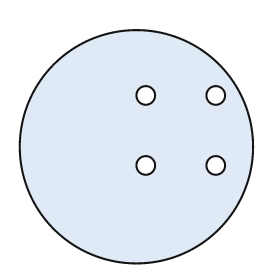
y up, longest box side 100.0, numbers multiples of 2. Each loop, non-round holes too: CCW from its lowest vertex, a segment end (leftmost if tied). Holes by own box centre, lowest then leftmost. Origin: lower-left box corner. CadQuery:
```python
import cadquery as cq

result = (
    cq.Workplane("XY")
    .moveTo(50.0, 50.0)
    .circle(50.0)
    .moveTo(54.0, 42.0)
    .circle(4.0)
    .moveTo(84.0, 42.0)
    .circle(4.0)
    .moveTo(54.0, 72.0)
    .circle(4.0)
    .moveTo(84.0, 72.0)
    .circle(4.0)
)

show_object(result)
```